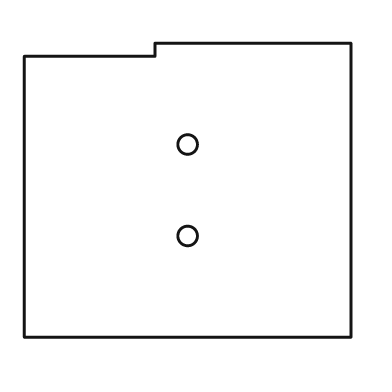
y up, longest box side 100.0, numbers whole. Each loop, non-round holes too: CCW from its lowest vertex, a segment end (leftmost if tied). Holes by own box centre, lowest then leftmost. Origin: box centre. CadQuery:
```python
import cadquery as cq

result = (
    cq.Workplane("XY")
    .moveTo(-50.0, -45.0)
    .lineTo(50.0, -45.0)
    .lineTo(50.0, 45.0)
    .lineTo(-10.0, 45.0)
    .lineTo(-10.0, 41.0)
    .lineTo(-50.0, 41.0)
    .close()
    .moveTo(0.0, -14.0)
    .circle(3.0)
    .moveTo(0.0, 14.0)
    .circle(3.0)
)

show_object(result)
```